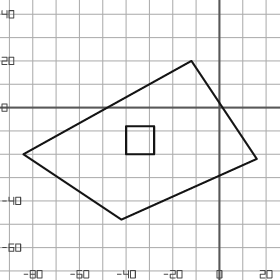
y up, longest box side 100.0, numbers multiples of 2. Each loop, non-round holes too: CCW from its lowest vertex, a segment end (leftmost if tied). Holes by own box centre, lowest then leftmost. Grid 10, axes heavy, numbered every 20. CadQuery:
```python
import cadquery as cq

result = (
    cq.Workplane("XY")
    .moveTo(-42.0, -48.0)
    .lineTo(16.0, -22.0)
    .lineTo(-12.0, 20.0)
    .lineTo(-84.0, -20.0)
    .close()
    .moveTo(-40.0, -20.0)
    .lineTo(-28.0, -20.0)
    .lineTo(-28.0, -8.0)
    .lineTo(-40.0, -8.0)
    .close()
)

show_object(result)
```